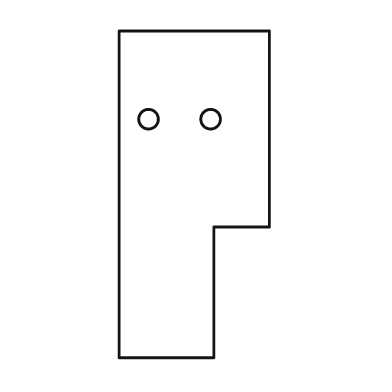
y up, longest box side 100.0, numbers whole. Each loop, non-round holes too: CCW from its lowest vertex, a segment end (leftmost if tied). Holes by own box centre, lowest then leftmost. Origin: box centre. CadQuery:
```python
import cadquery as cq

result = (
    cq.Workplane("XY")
    .moveTo(-23.0, -50.0)
    .lineTo(6.0, -50.0)
    .lineTo(6.0, -10.0)
    .lineTo(23.0, -10.0)
    .lineTo(23.0, 50.0)
    .lineTo(-23.0, 50.0)
    .close()
    .moveTo(-14.0, 23.0)
    .circle(3.0)
    .moveTo(5.0, 23.0)
    .circle(3.0)
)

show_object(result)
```